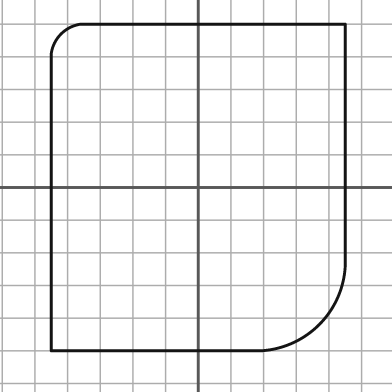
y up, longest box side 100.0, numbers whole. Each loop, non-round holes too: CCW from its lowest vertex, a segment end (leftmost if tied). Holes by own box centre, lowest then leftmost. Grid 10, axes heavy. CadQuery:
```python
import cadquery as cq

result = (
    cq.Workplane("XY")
    .moveTo(-45.0, -50.0)
    .lineTo(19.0, -50.0)
    .threePointArc((37.0, -42.0), (45.0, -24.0))
    .lineTo(45.0, 50.0)
    .lineTo(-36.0, 50.0)
    .threePointArc((-42.0, 47.0), (-45.0, 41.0))
    .close()
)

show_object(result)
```